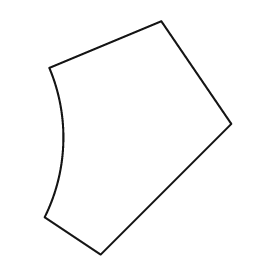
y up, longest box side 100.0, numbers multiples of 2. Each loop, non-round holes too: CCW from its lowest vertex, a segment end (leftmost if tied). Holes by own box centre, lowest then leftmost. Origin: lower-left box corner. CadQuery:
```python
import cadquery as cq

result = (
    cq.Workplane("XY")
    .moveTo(24.0, 0.0)
    .lineTo(80.0, 56.0)
    .lineTo(50.0, 100.0)
    .lineTo(2.0, 80.0)
    .threePointArc((8.0, 48.0), (0.0, 16.0))
    .close()
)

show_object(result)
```